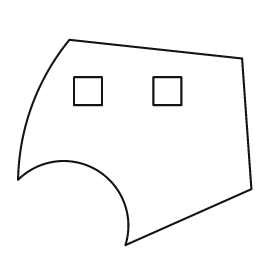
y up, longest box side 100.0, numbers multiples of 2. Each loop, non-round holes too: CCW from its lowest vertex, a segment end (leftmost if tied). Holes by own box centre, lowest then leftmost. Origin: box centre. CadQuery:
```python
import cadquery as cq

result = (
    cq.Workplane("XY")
    .moveTo(-4.0, -44.0)
    .lineTo(50.0, -20.0)
    .lineTo(46.0, 36.0)
    .lineTo(-28.0, 44.0)
    .threePointArc((-44.0, 16.0), (-50.0, -16.0))
    .threePointArc((-16.0, -12.0), (-4.0, -44.0))
    .close()
    .moveTo(-26.0, 16.0)
    .lineTo(-14.0, 16.0)
    .lineTo(-14.0, 28.0)
    .lineTo(-26.0, 28.0)
    .close()
    .moveTo(8.0, 16.0)
    .lineTo(20.0, 16.0)
    .lineTo(20.0, 28.0)
    .lineTo(8.0, 28.0)
    .close()
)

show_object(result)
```